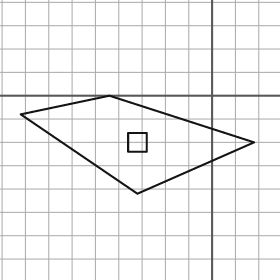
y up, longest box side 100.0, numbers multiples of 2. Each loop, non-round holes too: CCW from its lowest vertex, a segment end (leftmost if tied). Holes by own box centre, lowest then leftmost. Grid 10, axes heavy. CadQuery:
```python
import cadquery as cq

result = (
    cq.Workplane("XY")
    .moveTo(-32.0, -42.0)
    .lineTo(18.0, -20.0)
    .lineTo(-44.0, 0.0)
    .lineTo(-82.0, -8.0)
    .close()
    .moveTo(-36.0, -24.0)
    .lineTo(-28.0, -24.0)
    .lineTo(-28.0, -16.0)
    .lineTo(-36.0, -16.0)
    .close()
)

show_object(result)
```